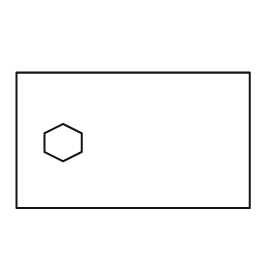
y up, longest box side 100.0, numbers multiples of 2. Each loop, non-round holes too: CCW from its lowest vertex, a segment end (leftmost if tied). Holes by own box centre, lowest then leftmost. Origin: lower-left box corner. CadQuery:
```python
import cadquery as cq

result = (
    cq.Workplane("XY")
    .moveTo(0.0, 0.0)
    .lineTo(100.0, 0.0)
    .lineTo(100.0, 58.0)
    .lineTo(0.0, 58.0)
    .close()
    .moveTo(20.0, 20.0)
    .lineTo(28.0, 24.0)
    .lineTo(28.0, 32.0)
    .lineTo(20.0, 36.0)
    .lineTo(12.0, 32.0)
    .lineTo(12.0, 24.0)
    .close()
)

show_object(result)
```